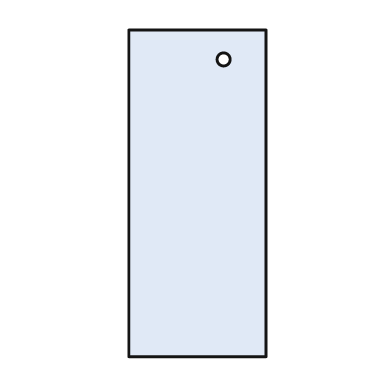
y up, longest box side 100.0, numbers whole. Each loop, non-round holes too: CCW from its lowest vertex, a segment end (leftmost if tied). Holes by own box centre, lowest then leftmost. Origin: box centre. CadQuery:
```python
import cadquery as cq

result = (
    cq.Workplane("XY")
    .moveTo(-21.0, -50.0)
    .lineTo(21.0, -50.0)
    .lineTo(21.0, 50.0)
    .lineTo(-21.0, 50.0)
    .close()
    .moveTo(8.0, 41.0)
    .circle(2.0)
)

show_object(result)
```